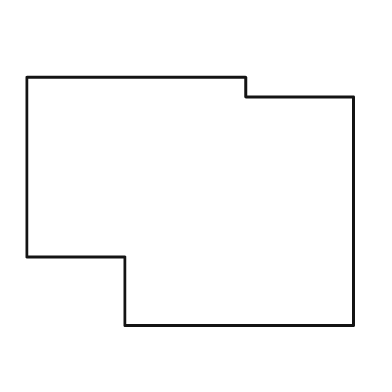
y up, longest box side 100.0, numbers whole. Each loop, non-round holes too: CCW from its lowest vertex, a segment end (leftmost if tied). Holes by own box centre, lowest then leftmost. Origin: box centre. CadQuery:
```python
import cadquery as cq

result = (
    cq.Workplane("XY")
    .moveTo(-20.0, -38.0)
    .lineTo(50.0, -38.0)
    .lineTo(50.0, 32.0)
    .lineTo(17.0, 32.0)
    .lineTo(17.0, 38.0)
    .lineTo(-50.0, 38.0)
    .lineTo(-50.0, -17.0)
    .lineTo(-20.0, -17.0)
    .close()
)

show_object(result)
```